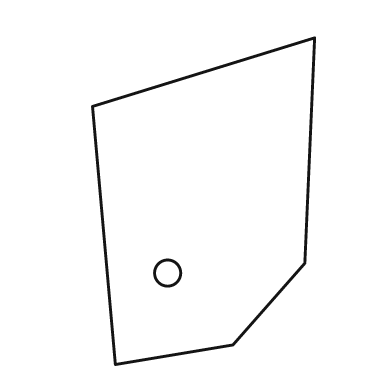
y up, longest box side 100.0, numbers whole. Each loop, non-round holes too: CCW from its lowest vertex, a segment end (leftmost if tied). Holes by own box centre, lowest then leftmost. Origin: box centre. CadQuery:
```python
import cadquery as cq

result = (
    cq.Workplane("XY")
    .moveTo(-27.0, -50.0)
    .lineTo(9.0, -44.0)
    .lineTo(31.0, -19.0)
    .lineTo(34.0, 50.0)
    .lineTo(-34.0, 29.0)
    .close()
    .moveTo(-11.0, -22.0)
    .circle(4.0)
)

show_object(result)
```